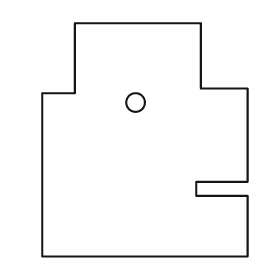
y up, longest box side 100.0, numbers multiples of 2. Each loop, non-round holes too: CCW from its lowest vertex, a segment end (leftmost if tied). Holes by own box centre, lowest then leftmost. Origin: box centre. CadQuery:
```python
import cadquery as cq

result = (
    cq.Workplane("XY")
    .moveTo(-44.0, -50.0)
    .lineTo(44.0, -50.0)
    .lineTo(44.0, -24.0)
    .lineTo(22.0, -24.0)
    .lineTo(22.0, -18.0)
    .lineTo(44.0, -18.0)
    .lineTo(44.0, 22.0)
    .lineTo(24.0, 22.0)
    .lineTo(24.0, 50.0)
    .lineTo(-30.0, 50.0)
    .lineTo(-30.0, 20.0)
    .lineTo(-44.0, 20.0)
    .close()
    .moveTo(-4.0, 16.0)
    .circle(4.0)
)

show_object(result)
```